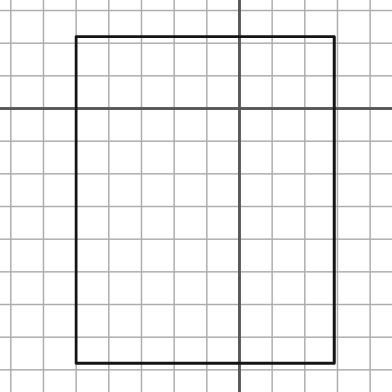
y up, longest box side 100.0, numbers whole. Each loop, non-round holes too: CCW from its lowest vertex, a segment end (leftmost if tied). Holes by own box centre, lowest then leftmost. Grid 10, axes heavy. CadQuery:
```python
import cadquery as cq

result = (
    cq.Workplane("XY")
    .moveTo(-50.0, -78.0)
    .lineTo(29.0, -78.0)
    .lineTo(29.0, 22.0)
    .lineTo(-50.0, 22.0)
    .close()
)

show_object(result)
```